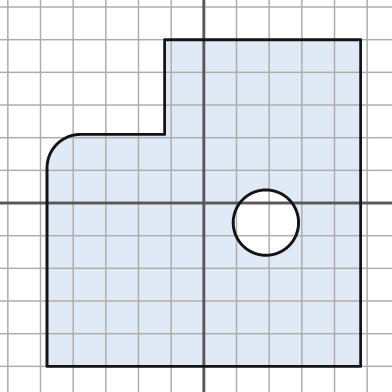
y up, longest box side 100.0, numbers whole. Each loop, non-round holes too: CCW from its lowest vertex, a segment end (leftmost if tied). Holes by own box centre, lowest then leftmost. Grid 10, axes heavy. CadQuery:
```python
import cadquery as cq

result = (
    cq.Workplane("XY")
    .moveTo(-48.0, -50.0)
    .lineTo(48.0, -50.0)
    .lineTo(48.0, 50.0)
    .lineTo(-12.0, 50.0)
    .lineTo(-12.0, 21.0)
    .lineTo(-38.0, 21.0)
    .threePointArc((-45.0, 18.0), (-48.0, 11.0))
    .close()
    .moveTo(19.0, -6.0)
    .circle(10.0)
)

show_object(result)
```